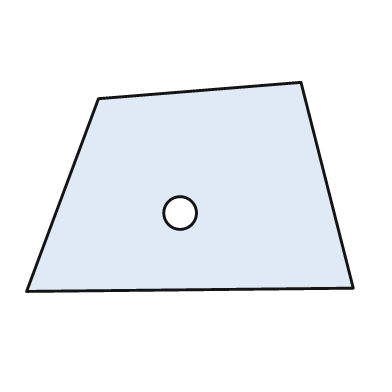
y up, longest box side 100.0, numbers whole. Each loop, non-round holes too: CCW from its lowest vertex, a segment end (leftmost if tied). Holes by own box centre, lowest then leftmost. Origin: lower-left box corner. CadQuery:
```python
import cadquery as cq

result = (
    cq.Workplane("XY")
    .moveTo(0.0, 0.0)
    .lineTo(100.0, 1.0)
    .lineTo(84.0, 64.0)
    .lineTo(22.0, 59.0)
    .close()
    .moveTo(47.0, 24.0)
    .circle(5.0)
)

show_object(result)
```